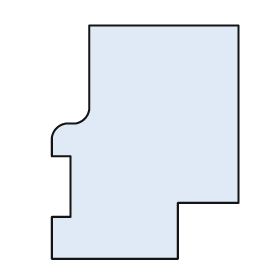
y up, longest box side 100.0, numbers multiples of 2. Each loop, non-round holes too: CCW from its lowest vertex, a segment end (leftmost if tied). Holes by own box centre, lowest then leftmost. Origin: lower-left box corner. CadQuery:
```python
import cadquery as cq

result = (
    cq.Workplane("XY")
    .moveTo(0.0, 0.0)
    .lineTo(54.0, 0.0)
    .lineTo(54.0, 24.0)
    .lineTo(80.0, 24.0)
    .lineTo(80.0, 100.0)
    .lineTo(16.0, 100.0)
    .lineTo(16.0, 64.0)
    .threePointArc((14.0, 60.0), (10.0, 58.0))
    .lineTo(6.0, 58.0)
    .threePointArc((2.0, 56.0), (0.0, 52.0))
    .lineTo(0.0, 44.0)
    .lineTo(8.0, 44.0)
    .lineTo(8.0, 18.0)
    .lineTo(0.0, 18.0)
    .close()
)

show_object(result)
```